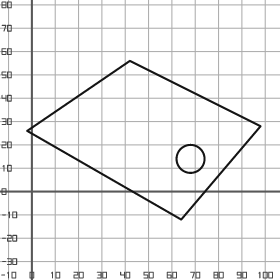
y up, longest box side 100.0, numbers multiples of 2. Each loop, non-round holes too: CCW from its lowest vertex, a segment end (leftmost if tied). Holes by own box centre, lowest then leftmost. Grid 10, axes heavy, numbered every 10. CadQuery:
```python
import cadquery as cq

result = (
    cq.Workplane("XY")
    .moveTo(64.0, -12.0)
    .lineTo(98.0, 28.0)
    .lineTo(42.0, 56.0)
    .lineTo(-2.0, 26.0)
    .close()
    .moveTo(68.0, 14.0)
    .circle(6.0)
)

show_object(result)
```